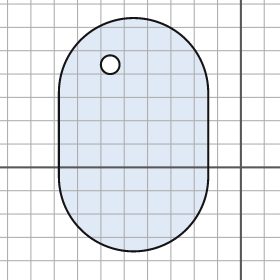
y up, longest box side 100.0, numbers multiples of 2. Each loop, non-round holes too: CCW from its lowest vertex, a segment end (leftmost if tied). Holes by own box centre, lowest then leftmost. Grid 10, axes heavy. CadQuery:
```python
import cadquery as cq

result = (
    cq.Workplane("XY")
    .moveTo(-78.0, -4.0)
    .threePointArc((-46.0, -36.0), (-14.0, -4.0))
    .lineTo(-14.0, 32.0)
    .threePointArc((-46.0, 64.0), (-78.0, 32.0))
    .close()
    .moveTo(-56.0, 44.0)
    .circle(4.0)
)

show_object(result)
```